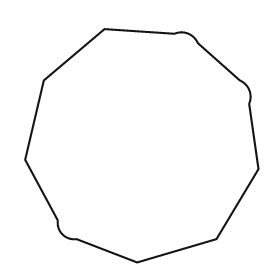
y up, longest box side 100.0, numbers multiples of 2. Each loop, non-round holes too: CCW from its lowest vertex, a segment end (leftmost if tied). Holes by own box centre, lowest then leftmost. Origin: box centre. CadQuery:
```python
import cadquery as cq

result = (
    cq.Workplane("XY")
    .moveTo(-2.0, -50.0)
    .lineTo(32.0, -40.0)
    .lineTo(50.0, -10.0)
    .lineTo(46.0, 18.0)
    .threePointArc((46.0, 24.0), (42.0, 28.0))
    .lineTo(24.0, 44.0)
    .threePointArc((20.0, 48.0), (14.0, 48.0))
    .lineTo(-16.0, 50.0)
    .lineTo(-42.0, 28.0)
    .lineTo(-50.0, -6.0)
    .lineTo(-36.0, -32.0)
    .threePointArc((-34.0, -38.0), (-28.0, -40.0))
    .close()
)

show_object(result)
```